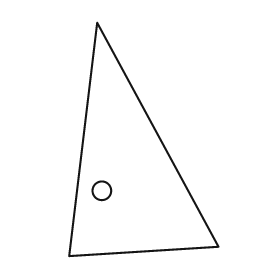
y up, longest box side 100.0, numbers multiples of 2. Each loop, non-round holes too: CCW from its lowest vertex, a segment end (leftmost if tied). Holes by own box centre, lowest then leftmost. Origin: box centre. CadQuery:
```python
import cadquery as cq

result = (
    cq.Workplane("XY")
    .moveTo(-32.0, -50.0)
    .lineTo(32.0, -46.0)
    .lineTo(-20.0, 50.0)
    .close()
    .moveTo(-18.0, -22.0)
    .circle(4.0)
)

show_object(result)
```